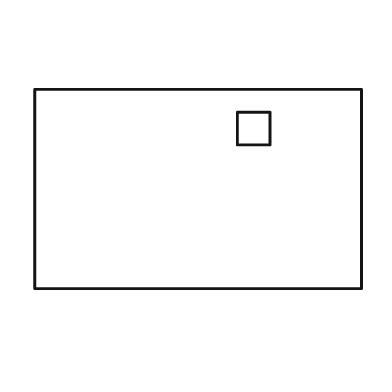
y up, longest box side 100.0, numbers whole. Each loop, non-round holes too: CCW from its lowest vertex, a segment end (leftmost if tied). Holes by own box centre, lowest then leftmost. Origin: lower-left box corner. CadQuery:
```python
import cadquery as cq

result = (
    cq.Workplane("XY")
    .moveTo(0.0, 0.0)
    .lineTo(100.0, 0.0)
    .lineTo(100.0, 61.0)
    .lineTo(0.0, 61.0)
    .close()
    .moveTo(62.0, 44.0)
    .lineTo(72.0, 44.0)
    .lineTo(72.0, 54.0)
    .lineTo(62.0, 54.0)
    .close()
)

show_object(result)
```